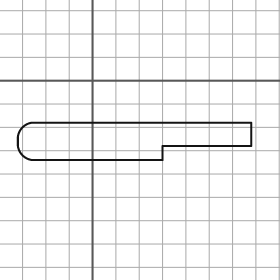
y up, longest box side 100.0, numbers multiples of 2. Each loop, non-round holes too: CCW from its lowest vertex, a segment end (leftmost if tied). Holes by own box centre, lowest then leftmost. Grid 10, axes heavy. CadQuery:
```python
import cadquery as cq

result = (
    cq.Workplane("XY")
    .moveTo(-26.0, -34.0)
    .lineTo(30.0, -34.0)
    .lineTo(30.0, -28.0)
    .lineTo(68.0, -28.0)
    .lineTo(68.0, -18.0)
    .lineTo(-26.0, -18.0)
    .threePointArc((-30.0, -20.0), (-32.0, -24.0))
    .lineTo(-32.0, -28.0)
    .threePointArc((-30.0, -32.0), (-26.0, -34.0))
    .close()
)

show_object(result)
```